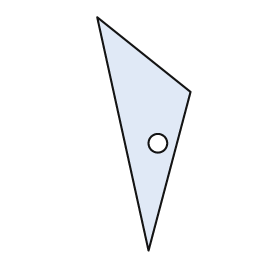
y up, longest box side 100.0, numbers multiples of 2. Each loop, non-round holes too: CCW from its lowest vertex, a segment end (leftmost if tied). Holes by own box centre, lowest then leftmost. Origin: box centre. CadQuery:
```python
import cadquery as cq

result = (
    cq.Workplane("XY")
    .moveTo(2.0, -50.0)
    .lineTo(20.0, 18.0)
    .lineTo(-20.0, 50.0)
    .close()
    .moveTo(6.0, -4.0)
    .circle(4.0)
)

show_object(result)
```